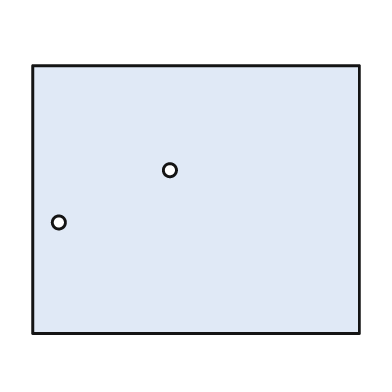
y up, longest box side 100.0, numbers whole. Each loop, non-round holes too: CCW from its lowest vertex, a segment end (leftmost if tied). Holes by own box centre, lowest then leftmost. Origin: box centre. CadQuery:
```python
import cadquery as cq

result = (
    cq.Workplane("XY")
    .moveTo(-50.0, -41.0)
    .lineTo(50.0, -41.0)
    .lineTo(50.0, 41.0)
    .lineTo(-50.0, 41.0)
    .close()
    .moveTo(-42.0, -7.0)
    .circle(2.0)
    .moveTo(-8.0, 9.0)
    .circle(2.0)
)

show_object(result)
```